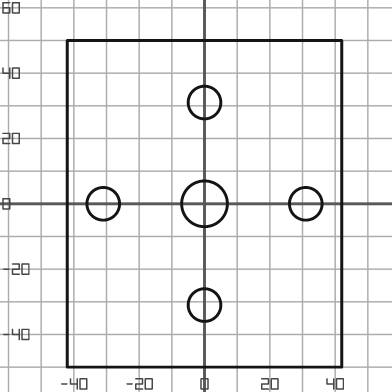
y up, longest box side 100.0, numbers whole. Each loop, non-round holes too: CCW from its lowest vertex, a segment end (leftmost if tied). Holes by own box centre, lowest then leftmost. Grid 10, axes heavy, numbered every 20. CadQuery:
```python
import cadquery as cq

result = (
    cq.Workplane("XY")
    .moveTo(-42.0, -50.0)
    .lineTo(42.0, -50.0)
    .lineTo(42.0, 50.0)
    .lineTo(-42.0, 50.0)
    .close()
    .moveTo(0.0, -31.0)
    .circle(5.0)
    .moveTo(-31.0, 0.0)
    .circle(5.0)
    .moveTo(0.0, 0.0)
    .circle(7.0)
    .moveTo(31.0, 0.0)
    .circle(5.0)
    .moveTo(0.0, 31.0)
    .circle(5.0)
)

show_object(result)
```